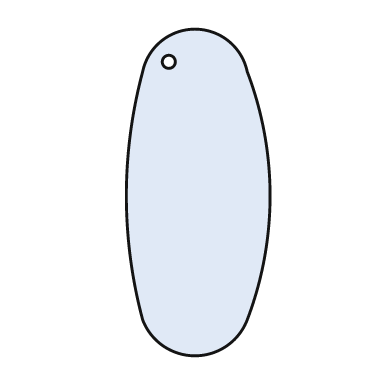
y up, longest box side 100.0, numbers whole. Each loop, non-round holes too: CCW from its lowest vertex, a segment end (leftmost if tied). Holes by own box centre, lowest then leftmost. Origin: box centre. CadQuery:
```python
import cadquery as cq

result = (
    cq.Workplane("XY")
    .moveTo(-17.0, -39.0)
    .threePointArc((-1.0, -50.0), (15.0, -39.0))
    .threePointArc((22.0, -1.0), (15.0, 37.0))
    .threePointArc((-1.0, 50.0), (-17.0, 37.0))
    .threePointArc((-22.0, -1.0), (-17.0, -39.0))
    .close()
    .moveTo(-9.0, 40.0)
    .circle(2.0)
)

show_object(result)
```